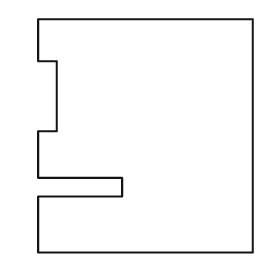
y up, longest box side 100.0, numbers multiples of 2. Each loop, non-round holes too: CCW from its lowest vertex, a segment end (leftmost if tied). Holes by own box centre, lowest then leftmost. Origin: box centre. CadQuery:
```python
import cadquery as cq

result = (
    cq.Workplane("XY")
    .moveTo(-46.0, -50.0)
    .lineTo(46.0, -50.0)
    .lineTo(46.0, 50.0)
    .lineTo(-46.0, 50.0)
    .lineTo(-46.0, 32.0)
    .lineTo(-38.0, 32.0)
    .lineTo(-38.0, 2.0)
    .lineTo(-46.0, 2.0)
    .lineTo(-46.0, -18.0)
    .lineTo(-10.0, -18.0)
    .lineTo(-10.0, -26.0)
    .lineTo(-46.0, -26.0)
    .close()
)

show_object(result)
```